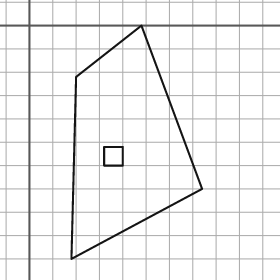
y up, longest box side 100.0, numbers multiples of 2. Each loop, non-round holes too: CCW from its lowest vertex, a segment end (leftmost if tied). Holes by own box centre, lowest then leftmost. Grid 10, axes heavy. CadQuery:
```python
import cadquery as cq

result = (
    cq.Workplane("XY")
    .moveTo(18.0, -100.0)
    .lineTo(74.0, -70.0)
    .lineTo(48.0, 0.0)
    .lineTo(20.0, -22.0)
    .close()
    .moveTo(32.0, -60.0)
    .lineTo(40.0, -60.0)
    .lineTo(40.0, -52.0)
    .lineTo(32.0, -52.0)
    .close()
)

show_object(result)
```